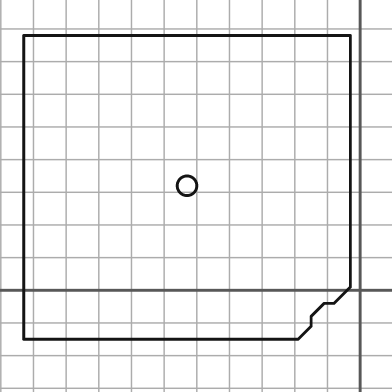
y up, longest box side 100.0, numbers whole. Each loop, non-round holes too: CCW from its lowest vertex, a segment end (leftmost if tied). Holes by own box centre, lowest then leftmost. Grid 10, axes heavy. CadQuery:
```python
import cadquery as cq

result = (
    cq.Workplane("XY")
    .moveTo(-103.0, -15.0)
    .lineTo(-19.0, -15.0)
    .lineTo(-15.0, -11.0)
    .lineTo(-15.0, -8.0)
    .lineTo(-11.0, -4.0)
    .lineTo(-8.0, -4.0)
    .lineTo(-3.0, 1.0)
    .lineTo(-3.0, 78.0)
    .lineTo(-103.0, 78.0)
    .close()
    .moveTo(-53.0, 32.0)
    .circle(3.0)
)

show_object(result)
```